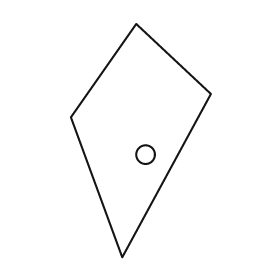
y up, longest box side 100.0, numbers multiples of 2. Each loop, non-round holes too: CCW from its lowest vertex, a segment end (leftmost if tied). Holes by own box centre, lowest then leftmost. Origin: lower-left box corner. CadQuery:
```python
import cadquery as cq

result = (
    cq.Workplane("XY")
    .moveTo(22.0, 0.0)
    .lineTo(60.0, 70.0)
    .lineTo(28.0, 100.0)
    .lineTo(0.0, 60.0)
    .close()
    .moveTo(32.0, 44.0)
    .circle(4.0)
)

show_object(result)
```